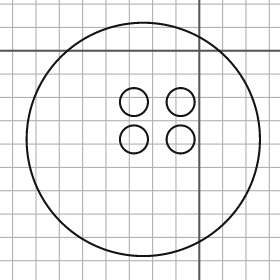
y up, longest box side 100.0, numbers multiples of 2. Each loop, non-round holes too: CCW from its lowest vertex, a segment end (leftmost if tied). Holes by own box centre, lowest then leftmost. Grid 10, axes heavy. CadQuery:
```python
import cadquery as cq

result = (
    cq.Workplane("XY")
    .moveTo(-24.0, -38.0)
    .circle(50.0)
    .moveTo(-28.0, -38.0)
    .circle(6.0)
    .moveTo(-8.0, -38.0)
    .circle(6.0)
    .moveTo(-28.0, -22.0)
    .circle(6.0)
    .moveTo(-8.0, -22.0)
    .circle(6.0)
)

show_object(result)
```